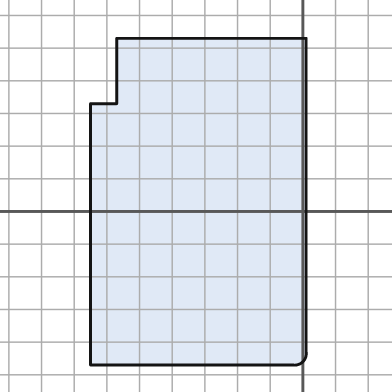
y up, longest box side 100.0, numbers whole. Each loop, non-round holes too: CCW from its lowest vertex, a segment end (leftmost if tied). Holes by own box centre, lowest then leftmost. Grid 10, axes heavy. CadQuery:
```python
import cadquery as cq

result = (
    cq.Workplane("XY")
    .moveTo(-65.0, -47.0)
    .lineTo(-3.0, -47.0)
    .threePointArc((0.0, -46.0), (1.0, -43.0))
    .lineTo(1.0, 53.0)
    .lineTo(-57.0, 53.0)
    .lineTo(-57.0, 33.0)
    .lineTo(-65.0, 33.0)
    .close()
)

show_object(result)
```